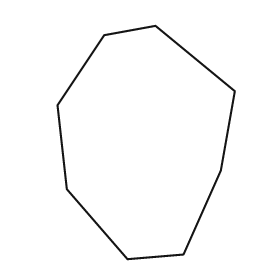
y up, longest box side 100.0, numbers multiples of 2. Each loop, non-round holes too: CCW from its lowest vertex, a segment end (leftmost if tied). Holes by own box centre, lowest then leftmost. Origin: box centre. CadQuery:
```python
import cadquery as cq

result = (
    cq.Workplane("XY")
    .moveTo(-8.0, -50.0)
    .lineTo(16.0, -48.0)
    .lineTo(32.0, -12.0)
    .lineTo(38.0, 22.0)
    .lineTo(4.0, 50.0)
    .lineTo(-18.0, 46.0)
    .lineTo(-38.0, 16.0)
    .lineTo(-34.0, -20.0)
    .close()
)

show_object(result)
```